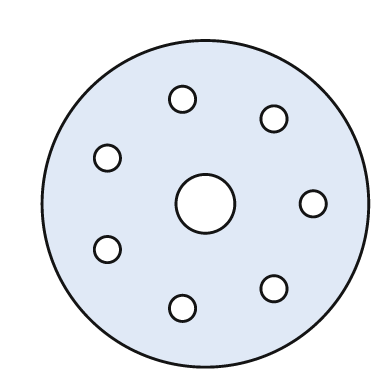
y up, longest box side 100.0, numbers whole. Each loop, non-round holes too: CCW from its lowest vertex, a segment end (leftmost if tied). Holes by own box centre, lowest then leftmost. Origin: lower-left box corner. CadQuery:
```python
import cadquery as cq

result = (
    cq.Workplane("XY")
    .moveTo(50.0, 50.0)
    .circle(50.0)
    .moveTo(43.0, 18.0)
    .circle(4.0)
    .moveTo(71.0, 24.0)
    .circle(4.0)
    .moveTo(20.0, 36.0)
    .circle(4.0)
    .moveTo(50.0, 50.0)
    .circle(9.0)
    .moveTo(83.0, 50.0)
    .circle(4.0)
    .moveTo(20.0, 64.0)
    .circle(4.0)
    .moveTo(71.0, 76.0)
    .circle(4.0)
    .moveTo(43.0, 82.0)
    .circle(4.0)
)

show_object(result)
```